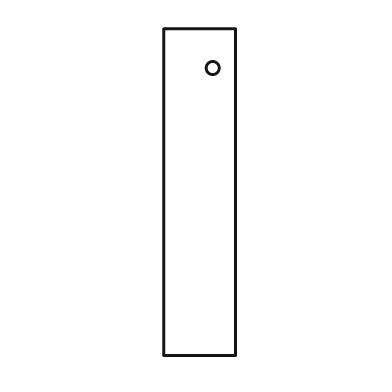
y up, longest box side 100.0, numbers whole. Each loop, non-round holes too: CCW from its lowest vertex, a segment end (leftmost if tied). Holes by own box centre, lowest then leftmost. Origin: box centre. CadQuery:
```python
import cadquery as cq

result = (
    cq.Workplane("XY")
    .moveTo(-11.0, -50.0)
    .lineTo(11.0, -50.0)
    .lineTo(11.0, 50.0)
    .lineTo(-11.0, 50.0)
    .close()
    .moveTo(4.0, 38.0)
    .circle(2.0)
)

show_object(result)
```